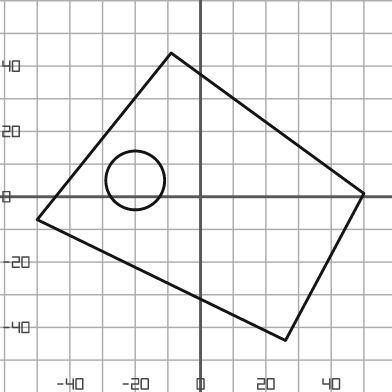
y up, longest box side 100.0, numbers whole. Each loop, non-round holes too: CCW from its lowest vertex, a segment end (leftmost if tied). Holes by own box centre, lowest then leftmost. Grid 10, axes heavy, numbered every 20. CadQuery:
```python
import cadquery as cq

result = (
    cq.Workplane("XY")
    .moveTo(26.0, -44.0)
    .lineTo(50.0, 1.0)
    .lineTo(-9.0, 44.0)
    .lineTo(-50.0, -7.0)
    .close()
    .moveTo(-20.0, 5.0)
    .circle(9.0)
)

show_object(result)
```